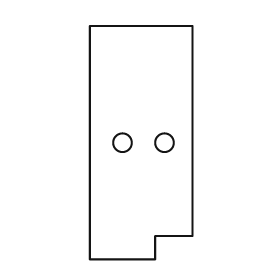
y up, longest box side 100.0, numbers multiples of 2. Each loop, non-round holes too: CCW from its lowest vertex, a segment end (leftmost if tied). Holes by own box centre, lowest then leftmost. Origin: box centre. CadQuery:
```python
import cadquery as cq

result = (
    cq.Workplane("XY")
    .moveTo(-22.0, -50.0)
    .lineTo(6.0, -50.0)
    .lineTo(6.0, -40.0)
    .lineTo(22.0, -40.0)
    .lineTo(22.0, 50.0)
    .lineTo(-22.0, 50.0)
    .close()
    .moveTo(-8.0, 0.0)
    .circle(4.0)
    .moveTo(10.0, 0.0)
    .circle(4.0)
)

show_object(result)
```